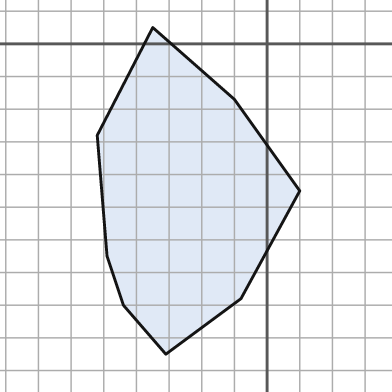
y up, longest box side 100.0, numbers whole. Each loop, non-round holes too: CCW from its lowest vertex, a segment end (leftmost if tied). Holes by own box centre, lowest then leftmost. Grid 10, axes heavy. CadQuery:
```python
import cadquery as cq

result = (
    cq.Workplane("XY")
    .moveTo(-31.0, -95.0)
    .lineTo(-8.0, -78.0)
    .lineTo(10.0, -45.0)
    .lineTo(-10.0, -17.0)
    .lineTo(-35.0, 5.0)
    .lineTo(-52.0, -28.0)
    .lineTo(-49.0, -65.0)
    .lineTo(-44.0, -80.0)
    .close()
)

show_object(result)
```